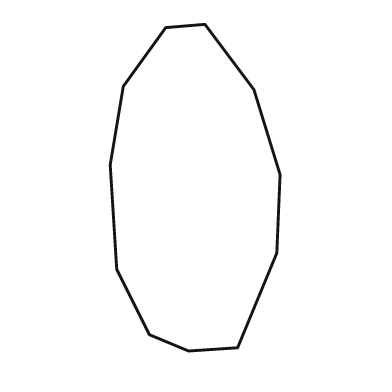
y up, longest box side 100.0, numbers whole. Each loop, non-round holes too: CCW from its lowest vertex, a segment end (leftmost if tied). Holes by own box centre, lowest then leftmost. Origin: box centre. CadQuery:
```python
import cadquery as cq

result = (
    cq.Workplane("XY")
    .moveTo(-2.0, -50.0)
    .lineTo(13.0, -49.0)
    .lineTo(25.0, -20.0)
    .lineTo(26.0, 4.0)
    .lineTo(18.0, 30.0)
    .lineTo(3.0, 50.0)
    .lineTo(-9.0, 49.0)
    .lineTo(-22.0, 31.0)
    .lineTo(-26.0, 7.0)
    .lineTo(-24.0, -25.0)
    .lineTo(-14.0, -45.0)
    .close()
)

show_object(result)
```